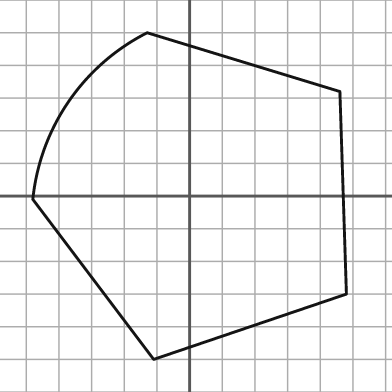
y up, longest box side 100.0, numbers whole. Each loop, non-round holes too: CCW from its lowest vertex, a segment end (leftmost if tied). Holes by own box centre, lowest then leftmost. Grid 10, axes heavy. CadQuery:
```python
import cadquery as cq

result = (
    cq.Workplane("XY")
    .moveTo(-11.0, -50.0)
    .lineTo(48.0, -30.0)
    .lineTo(46.0, 32.0)
    .lineTo(-13.0, 50.0)
    .threePointArc((-37.0, 29.0), (-48.0, -1.0))
    .close()
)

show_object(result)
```